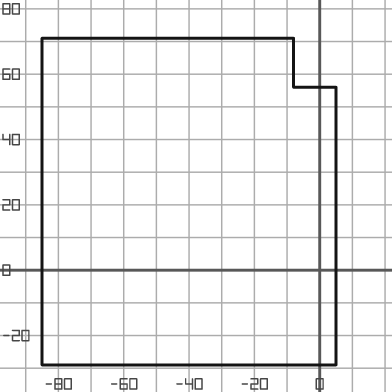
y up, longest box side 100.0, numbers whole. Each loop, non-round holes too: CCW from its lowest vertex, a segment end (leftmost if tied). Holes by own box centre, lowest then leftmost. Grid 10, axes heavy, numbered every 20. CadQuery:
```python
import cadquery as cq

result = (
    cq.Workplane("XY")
    .moveTo(-85.0, -29.0)
    .lineTo(5.0, -29.0)
    .lineTo(5.0, 56.0)
    .lineTo(-8.0, 56.0)
    .lineTo(-8.0, 71.0)
    .lineTo(-85.0, 71.0)
    .close()
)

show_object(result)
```